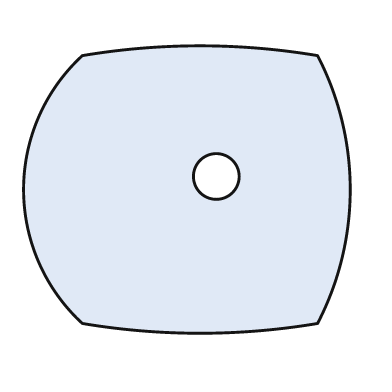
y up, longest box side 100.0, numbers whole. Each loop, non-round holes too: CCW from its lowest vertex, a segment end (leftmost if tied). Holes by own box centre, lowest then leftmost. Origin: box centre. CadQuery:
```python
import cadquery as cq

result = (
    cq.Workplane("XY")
    .moveTo(-32.0, -41.0)
    .threePointArc((4.0, -44.0), (40.0, -41.0))
    .threePointArc((50.0, 0.0), (40.0, 41.0))
    .threePointArc((4.0, 44.0), (-32.0, 41.0))
    .threePointArc((-50.0, 0.0), (-32.0, -41.0))
    .close()
    .moveTo(9.0, 4.0)
    .circle(7.0)
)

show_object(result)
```